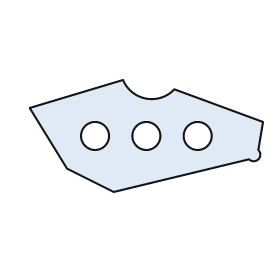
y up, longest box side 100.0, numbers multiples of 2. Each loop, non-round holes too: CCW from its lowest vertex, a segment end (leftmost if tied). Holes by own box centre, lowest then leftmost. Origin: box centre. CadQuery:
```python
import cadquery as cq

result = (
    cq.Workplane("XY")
    .moveTo(-14.0, -24.0)
    .lineTo(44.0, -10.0)
    .threePointArc((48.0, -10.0), (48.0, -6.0))
    .lineTo(50.0, 6.0)
    .lineTo(12.0, 20.0)
    .threePointArc((0.0, 16.0), (-10.0, 24.0))
    .lineTo(-50.0, 12.0)
    .lineTo(-34.0, -14.0)
    .close()
    .moveTo(-22.0, 0.0)
    .circle(6.0)
    .moveTo(0.0, 0.0)
    .circle(6.0)
    .moveTo(22.0, 0.0)
    .circle(6.0)
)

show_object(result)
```